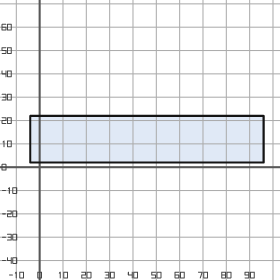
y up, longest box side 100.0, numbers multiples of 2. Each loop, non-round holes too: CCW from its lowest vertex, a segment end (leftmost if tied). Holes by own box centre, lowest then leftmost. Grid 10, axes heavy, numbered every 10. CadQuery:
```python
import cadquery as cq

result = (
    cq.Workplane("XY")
    .moveTo(-4.0, 2.0)
    .lineTo(96.0, 2.0)
    .lineTo(96.0, 22.0)
    .lineTo(-4.0, 22.0)
    .close()
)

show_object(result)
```